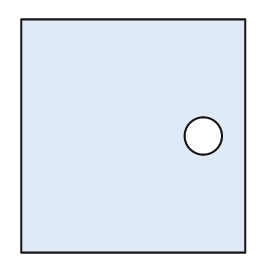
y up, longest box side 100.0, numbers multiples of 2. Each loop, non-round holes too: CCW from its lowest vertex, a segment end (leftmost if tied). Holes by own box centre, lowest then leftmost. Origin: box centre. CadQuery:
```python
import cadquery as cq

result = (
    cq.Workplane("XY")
    .moveTo(-48.0, -50.0)
    .lineTo(48.0, -50.0)
    .lineTo(48.0, 50.0)
    .lineTo(-48.0, 50.0)
    .close()
    .moveTo(30.0, 0.0)
    .circle(8.0)
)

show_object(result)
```